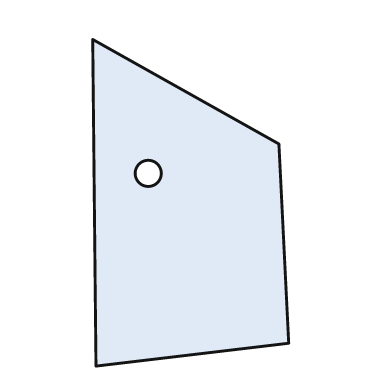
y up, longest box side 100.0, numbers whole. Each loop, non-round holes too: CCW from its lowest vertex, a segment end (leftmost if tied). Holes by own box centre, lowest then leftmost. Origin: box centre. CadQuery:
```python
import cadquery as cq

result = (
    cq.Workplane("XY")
    .moveTo(-29.0, -50.0)
    .lineTo(30.0, -43.0)
    .lineTo(27.0, 18.0)
    .lineTo(-30.0, 50.0)
    .close()
    .moveTo(-13.0, 9.0)
    .circle(4.0)
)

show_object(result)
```